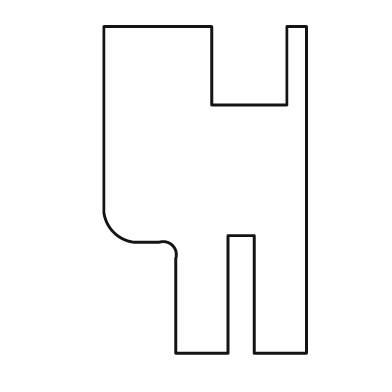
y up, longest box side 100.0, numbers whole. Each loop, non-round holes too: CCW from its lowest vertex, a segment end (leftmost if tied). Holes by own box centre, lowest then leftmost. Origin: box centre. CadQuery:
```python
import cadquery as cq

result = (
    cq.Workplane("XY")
    .moveTo(-9.0, -50.0)
    .lineTo(7.0, -50.0)
    .lineTo(7.0, -14.0)
    .lineTo(15.0, -14.0)
    .lineTo(15.0, -50.0)
    .lineTo(31.0, -50.0)
    .lineTo(31.0, 50.0)
    .lineTo(25.0, 50.0)
    .lineTo(25.0, 26.0)
    .lineTo(2.0, 26.0)
    .lineTo(2.0, 50.0)
    .lineTo(-31.0, 50.0)
    .lineTo(-31.0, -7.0)
    .threePointArc((-28.0, -13.0), (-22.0, -16.0))
    .lineTo(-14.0, -16.0)
    .threePointArc((-10.0, -17.0), (-9.0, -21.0))
    .close()
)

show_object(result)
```